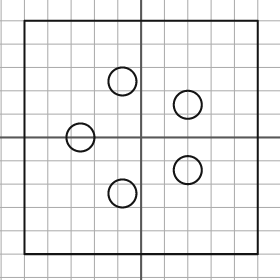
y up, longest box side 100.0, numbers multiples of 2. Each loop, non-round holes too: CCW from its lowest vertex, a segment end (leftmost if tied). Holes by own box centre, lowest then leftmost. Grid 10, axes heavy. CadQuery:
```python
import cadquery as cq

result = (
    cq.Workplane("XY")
    .moveTo(-50.0, -50.0)
    .lineTo(50.0, -50.0)
    .lineTo(50.0, 50.0)
    .lineTo(-50.0, 50.0)
    .close()
    .moveTo(-8.0, -24.0)
    .circle(6.0)
    .moveTo(20.0, -14.0)
    .circle(6.0)
    .moveTo(-26.0, 0.0)
    .circle(6.0)
    .moveTo(20.0, 14.0)
    .circle(6.0)
    .moveTo(-8.0, 24.0)
    .circle(6.0)
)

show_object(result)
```